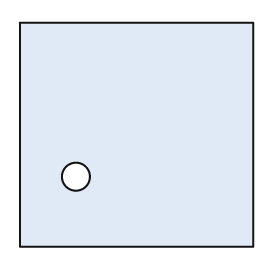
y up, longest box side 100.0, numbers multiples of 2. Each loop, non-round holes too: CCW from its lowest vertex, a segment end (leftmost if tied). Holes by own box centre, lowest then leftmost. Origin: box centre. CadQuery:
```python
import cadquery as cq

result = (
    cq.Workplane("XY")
    .moveTo(-50.0, -48.0)
    .lineTo(50.0, -48.0)
    .lineTo(50.0, 48.0)
    .lineTo(-50.0, 48.0)
    .close()
    .moveTo(-26.0, -18.0)
    .circle(6.0)
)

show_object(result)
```